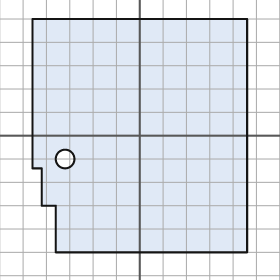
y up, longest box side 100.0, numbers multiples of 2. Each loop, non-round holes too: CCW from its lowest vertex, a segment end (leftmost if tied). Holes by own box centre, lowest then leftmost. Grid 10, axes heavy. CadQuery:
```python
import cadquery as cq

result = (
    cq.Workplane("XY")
    .moveTo(-36.0, -50.0)
    .lineTo(46.0, -50.0)
    .lineTo(46.0, 50.0)
    .lineTo(-46.0, 50.0)
    .lineTo(-46.0, -14.0)
    .lineTo(-42.0, -14.0)
    .lineTo(-42.0, -30.0)
    .lineTo(-36.0, -30.0)
    .close()
    .moveTo(-32.0, -10.0)
    .circle(4.0)
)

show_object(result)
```